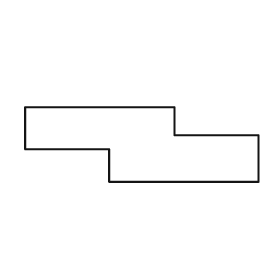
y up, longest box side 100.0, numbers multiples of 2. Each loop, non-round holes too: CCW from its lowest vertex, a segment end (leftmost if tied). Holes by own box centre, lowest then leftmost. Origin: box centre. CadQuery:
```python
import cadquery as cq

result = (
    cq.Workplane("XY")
    .moveTo(-14.0, -16.0)
    .lineTo(50.0, -16.0)
    .lineTo(50.0, 4.0)
    .lineTo(14.0, 4.0)
    .lineTo(14.0, 16.0)
    .lineTo(-50.0, 16.0)
    .lineTo(-50.0, -2.0)
    .lineTo(-14.0, -2.0)
    .close()
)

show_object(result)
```